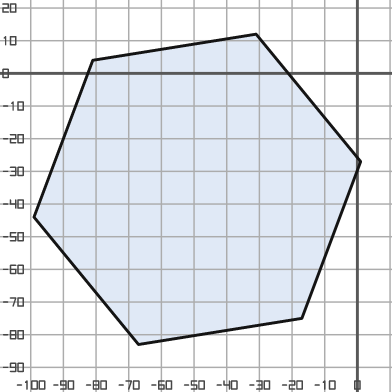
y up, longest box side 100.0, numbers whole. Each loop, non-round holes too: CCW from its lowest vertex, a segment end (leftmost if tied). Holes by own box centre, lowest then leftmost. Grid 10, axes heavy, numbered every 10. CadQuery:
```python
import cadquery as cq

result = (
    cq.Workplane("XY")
    .moveTo(-67.0, -83.0)
    .lineTo(-17.0, -75.0)
    .lineTo(1.0, -27.0)
    .lineTo(-31.0, 12.0)
    .lineTo(-81.0, 4.0)
    .lineTo(-99.0, -44.0)
    .close()
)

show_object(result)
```